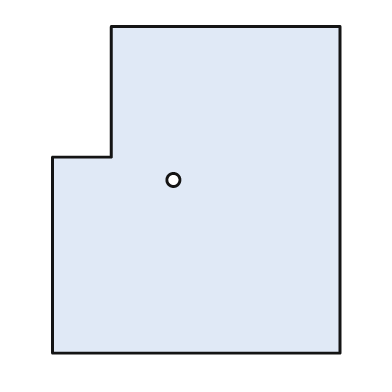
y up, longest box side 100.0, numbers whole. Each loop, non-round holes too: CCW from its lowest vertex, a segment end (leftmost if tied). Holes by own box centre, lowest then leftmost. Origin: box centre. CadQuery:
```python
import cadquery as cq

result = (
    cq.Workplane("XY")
    .moveTo(-44.0, -50.0)
    .lineTo(44.0, -50.0)
    .lineTo(44.0, 50.0)
    .lineTo(-26.0, 50.0)
    .lineTo(-26.0, 10.0)
    .lineTo(-44.0, 10.0)
    .close()
    .moveTo(-7.0, 3.0)
    .circle(2.0)
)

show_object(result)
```